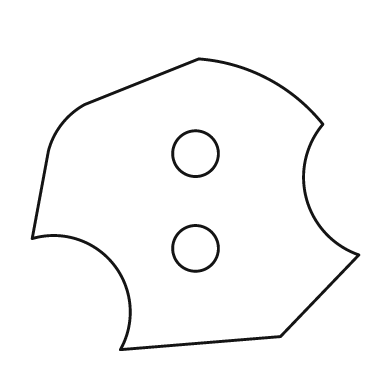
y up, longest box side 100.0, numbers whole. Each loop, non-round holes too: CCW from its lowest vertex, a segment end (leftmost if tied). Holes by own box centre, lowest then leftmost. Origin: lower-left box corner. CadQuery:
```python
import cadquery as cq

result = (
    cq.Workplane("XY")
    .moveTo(27.0, 0.0)
    .lineTo(76.0, 4.0)
    .lineTo(100.0, 29.0)
    .threePointArc((84.0, 46.0), (89.0, 69.0))
    .threePointArc((72.0, 83.0), (51.0, 89.0))
    .lineTo(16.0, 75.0)
    .threePointArc((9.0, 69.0), (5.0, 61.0))
    .lineTo(0.0, 34.0)
    .threePointArc((25.0, 26.0), (27.0, 0.0))
    .close()
    .moveTo(50.0, 31.0)
    .circle(7.0)
    .moveTo(50.0, 60.0)
    .circle(7.0)
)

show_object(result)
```